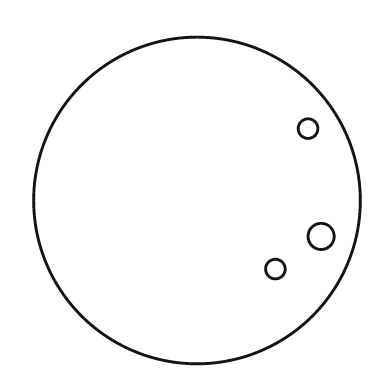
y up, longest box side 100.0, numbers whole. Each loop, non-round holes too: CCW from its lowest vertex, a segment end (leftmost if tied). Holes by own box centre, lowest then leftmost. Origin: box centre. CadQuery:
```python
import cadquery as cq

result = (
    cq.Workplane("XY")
    .moveTo(0.0, 0.0)
    .circle(50.0)
    .moveTo(24.0, -21.0)
    .circle(3.0)
    .moveTo(38.0, -11.0)
    .circle(4.0)
    .moveTo(34.0, 22.0)
    .circle(3.0)
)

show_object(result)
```